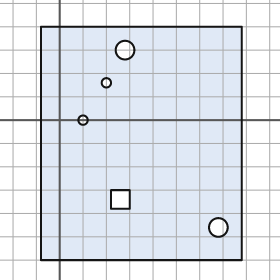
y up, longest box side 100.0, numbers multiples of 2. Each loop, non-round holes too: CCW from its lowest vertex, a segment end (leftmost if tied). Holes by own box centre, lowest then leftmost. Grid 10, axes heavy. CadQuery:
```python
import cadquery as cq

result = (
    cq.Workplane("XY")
    .moveTo(-8.0, -60.0)
    .lineTo(78.0, -60.0)
    .lineTo(78.0, 40.0)
    .lineTo(-8.0, 40.0)
    .close()
    .moveTo(68.0, -46.0)
    .circle(4.0)
    .moveTo(22.0, -38.0)
    .lineTo(30.0, -38.0)
    .lineTo(30.0, -30.0)
    .lineTo(22.0, -30.0)
    .close()
    .moveTo(10.0, 0.0)
    .circle(2.0)
    .moveTo(20.0, 16.0)
    .circle(2.0)
    .moveTo(28.0, 30.0)
    .circle(4.0)
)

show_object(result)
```